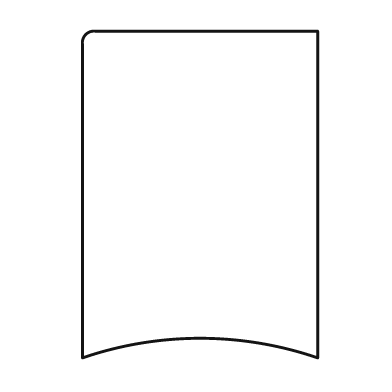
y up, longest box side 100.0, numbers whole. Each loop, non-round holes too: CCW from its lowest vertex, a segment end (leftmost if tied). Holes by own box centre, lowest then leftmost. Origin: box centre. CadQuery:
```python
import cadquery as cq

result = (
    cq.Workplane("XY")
    .moveTo(-36.0, -50.0)
    .threePointArc((0.0, -44.0), (36.0, -50.0))
    .lineTo(36.0, 50.0)
    .lineTo(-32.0, 50.0)
    .threePointArc((-35.0, 49.0), (-36.0, 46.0))
    .close()
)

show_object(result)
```